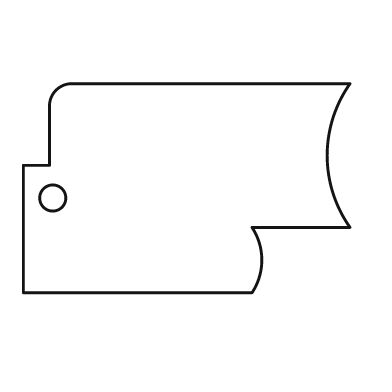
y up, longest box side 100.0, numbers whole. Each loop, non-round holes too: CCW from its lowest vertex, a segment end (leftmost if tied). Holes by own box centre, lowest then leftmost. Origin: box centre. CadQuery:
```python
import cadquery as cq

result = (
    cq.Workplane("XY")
    .moveTo(-50.0, -32.0)
    .lineTo(20.0, -32.0)
    .threePointArc((23.0, -22.0), (20.0, -12.0))
    .lineTo(50.0, -12.0)
    .threePointArc((43.0, 10.0), (50.0, 32.0))
    .lineTo(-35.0, 32.0)
    .threePointArc((-40.0, 30.0), (-42.0, 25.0))
    .lineTo(-42.0, 7.0)
    .lineTo(-50.0, 7.0)
    .close()
    .moveTo(-41.0, -3.0)
    .circle(4.0)
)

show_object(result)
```